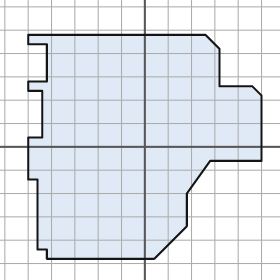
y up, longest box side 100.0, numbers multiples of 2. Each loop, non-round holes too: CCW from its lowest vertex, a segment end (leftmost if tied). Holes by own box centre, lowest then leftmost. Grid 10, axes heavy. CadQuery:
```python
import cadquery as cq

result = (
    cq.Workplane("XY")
    .moveTo(-42.0, -48.0)
    .lineTo(4.0, -48.0)
    .lineTo(18.0, -34.0)
    .lineTo(18.0, -20.0)
    .lineTo(28.0, -6.0)
    .lineTo(50.0, -6.0)
    .lineTo(50.0, 22.0)
    .lineTo(46.0, 26.0)
    .lineTo(32.0, 26.0)
    .lineTo(32.0, 42.0)
    .lineTo(26.0, 48.0)
    .lineTo(-50.0, 48.0)
    .lineTo(-50.0, 44.0)
    .lineTo(-42.0, 44.0)
    .lineTo(-42.0, 28.0)
    .lineTo(-50.0, 28.0)
    .lineTo(-50.0, 24.0)
    .lineTo(-44.0, 24.0)
    .lineTo(-44.0, 4.0)
    .lineTo(-50.0, 4.0)
    .lineTo(-50.0, -14.0)
    .lineTo(-46.0, -14.0)
    .lineTo(-46.0, -44.0)
    .lineTo(-42.0, -44.0)
    .close()
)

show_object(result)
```